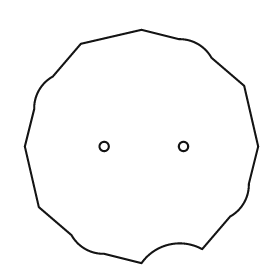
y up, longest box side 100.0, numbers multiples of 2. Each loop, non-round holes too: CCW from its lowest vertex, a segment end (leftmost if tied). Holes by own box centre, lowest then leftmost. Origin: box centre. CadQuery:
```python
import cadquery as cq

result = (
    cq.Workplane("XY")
    .moveTo(0.0, -50.0)
    .threePointArc((12.0, -42.0), (26.0, -44.0))
    .lineTo(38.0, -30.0)
    .threePointArc((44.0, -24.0), (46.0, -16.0))
    .lineTo(50.0, 0.0)
    .lineTo(44.0, 26.0)
    .lineTo(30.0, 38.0)
    .threePointArc((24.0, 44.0), (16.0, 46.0))
    .lineTo(0.0, 50.0)
    .lineTo(-26.0, 44.0)
    .lineTo(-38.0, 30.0)
    .threePointArc((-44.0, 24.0), (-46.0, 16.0))
    .lineTo(-50.0, 0.0)
    .lineTo(-44.0, -26.0)
    .lineTo(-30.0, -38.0)
    .threePointArc((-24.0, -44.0), (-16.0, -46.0))
    .close()
    .moveTo(-16.0, 0.0)
    .circle(2.0)
    .moveTo(18.0, 0.0)
    .circle(2.0)
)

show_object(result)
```